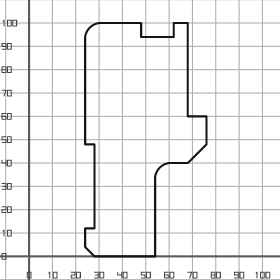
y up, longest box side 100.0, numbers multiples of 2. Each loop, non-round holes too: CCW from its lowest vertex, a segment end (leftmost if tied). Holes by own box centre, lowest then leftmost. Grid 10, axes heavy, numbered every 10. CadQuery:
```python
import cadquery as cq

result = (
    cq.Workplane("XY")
    .moveTo(28.0, 0.0)
    .lineTo(54.0, 0.0)
    .lineTo(54.0, 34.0)
    .threePointArc((56.0, 38.0), (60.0, 40.0))
    .lineTo(68.0, 40.0)
    .lineTo(76.0, 48.0)
    .lineTo(76.0, 60.0)
    .lineTo(68.0, 60.0)
    .lineTo(68.0, 100.0)
    .lineTo(62.0, 100.0)
    .lineTo(62.0, 94.0)
    .lineTo(48.0, 94.0)
    .lineTo(48.0, 100.0)
    .lineTo(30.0, 100.0)
    .threePointArc((26.0, 98.0), (24.0, 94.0))
    .lineTo(24.0, 48.0)
    .lineTo(28.0, 48.0)
    .lineTo(28.0, 12.0)
    .lineTo(24.0, 12.0)
    .lineTo(24.0, 4.0)
    .close()
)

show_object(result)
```